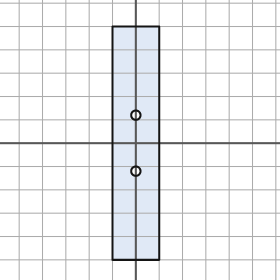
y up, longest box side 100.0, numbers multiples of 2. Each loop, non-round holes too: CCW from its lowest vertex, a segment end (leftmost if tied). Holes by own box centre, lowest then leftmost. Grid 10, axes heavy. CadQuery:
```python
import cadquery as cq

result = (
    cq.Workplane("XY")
    .moveTo(-10.0, -50.0)
    .lineTo(10.0, -50.0)
    .lineTo(10.0, 50.0)
    .lineTo(-10.0, 50.0)
    .close()
    .moveTo(0.0, -12.0)
    .circle(2.0)
    .moveTo(0.0, 12.0)
    .circle(2.0)
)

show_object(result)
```